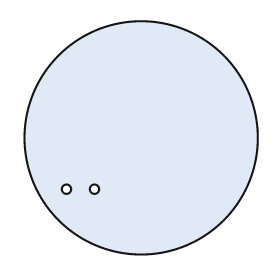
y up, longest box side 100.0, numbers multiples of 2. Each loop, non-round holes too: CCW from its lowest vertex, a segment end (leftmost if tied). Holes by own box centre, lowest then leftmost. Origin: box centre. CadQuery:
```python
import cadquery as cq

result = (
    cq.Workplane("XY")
    .moveTo(0.0, 0.0)
    .circle(50.0)
    .moveTo(-32.0, -22.0)
    .circle(2.0)
    .moveTo(-20.0, -22.0)
    .circle(2.0)
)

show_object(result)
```